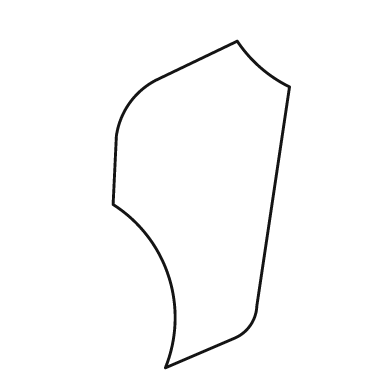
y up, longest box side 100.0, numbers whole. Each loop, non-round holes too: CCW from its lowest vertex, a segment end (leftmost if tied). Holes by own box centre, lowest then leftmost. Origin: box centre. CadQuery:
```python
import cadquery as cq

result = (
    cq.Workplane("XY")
    .moveTo(-11.0, -50.0)
    .lineTo(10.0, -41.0)
    .threePointArc((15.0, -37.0), (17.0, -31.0))
    .lineTo(27.0, 36.0)
    .threePointArc((18.0, 42.0), (11.0, 50.0))
    .lineTo(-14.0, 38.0)
    .threePointArc((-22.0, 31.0), (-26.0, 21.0))
    .lineTo(-27.0, 0.0)
    .threePointArc((-10.0, -22.0), (-11.0, -50.0))
    .close()
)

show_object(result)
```